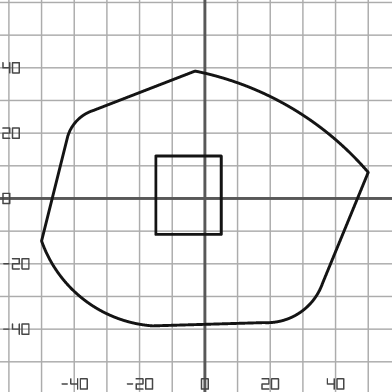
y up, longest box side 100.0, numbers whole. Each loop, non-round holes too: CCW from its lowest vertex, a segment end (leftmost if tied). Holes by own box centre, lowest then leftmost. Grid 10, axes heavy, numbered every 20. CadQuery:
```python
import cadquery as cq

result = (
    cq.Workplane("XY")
    .moveTo(-16.0, -39.0)
    .lineTo(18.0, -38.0)
    .threePointArc((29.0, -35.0), (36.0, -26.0))
    .lineTo(50.0, 8.0)
    .threePointArc((26.0, 28.0), (-3.0, 39.0))
    .lineTo(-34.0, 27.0)
    .threePointArc((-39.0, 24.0), (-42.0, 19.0))
    .lineTo(-50.0, -13.0)
    .threePointArc((-37.0, -31.0), (-16.0, -39.0))
    .close()
    .moveTo(-15.0, -11.0)
    .lineTo(5.0, -11.0)
    .lineTo(5.0, 13.0)
    .lineTo(-15.0, 13.0)
    .close()
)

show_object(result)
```